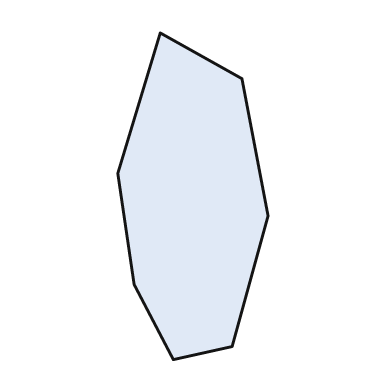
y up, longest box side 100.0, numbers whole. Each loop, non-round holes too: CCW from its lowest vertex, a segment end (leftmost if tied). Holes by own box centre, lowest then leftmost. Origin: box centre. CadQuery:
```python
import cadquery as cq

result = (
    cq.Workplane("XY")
    .moveTo(-6.0, -50.0)
    .lineTo(12.0, -46.0)
    .lineTo(23.0, -6.0)
    .lineTo(15.0, 36.0)
    .lineTo(-10.0, 50.0)
    .lineTo(-23.0, 7.0)
    .lineTo(-18.0, -27.0)
    .close()
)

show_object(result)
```